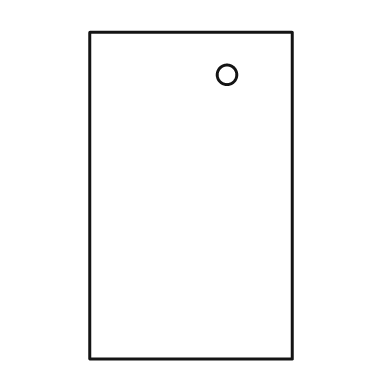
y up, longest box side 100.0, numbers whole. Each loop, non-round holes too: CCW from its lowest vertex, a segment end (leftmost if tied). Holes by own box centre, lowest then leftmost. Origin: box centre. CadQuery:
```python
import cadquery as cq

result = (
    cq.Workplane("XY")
    .moveTo(-31.0, -50.0)
    .lineTo(31.0, -50.0)
    .lineTo(31.0, 50.0)
    .lineTo(-31.0, 50.0)
    .close()
    .moveTo(11.0, 37.0)
    .circle(3.0)
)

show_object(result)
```